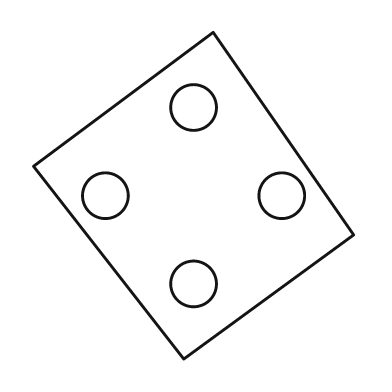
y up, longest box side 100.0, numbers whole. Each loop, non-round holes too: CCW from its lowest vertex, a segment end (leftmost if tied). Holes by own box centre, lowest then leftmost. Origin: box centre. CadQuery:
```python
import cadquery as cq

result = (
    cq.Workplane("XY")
    .moveTo(-3.0, -50.0)
    .lineTo(49.0, -12.0)
    .lineTo(6.0, 50.0)
    .lineTo(-49.0, 9.0)
    .close()
    .moveTo(0.0, -27.0)
    .circle(7.0)
    .moveTo(-27.0, 0.0)
    .circle(7.0)
    .moveTo(27.0, 0.0)
    .circle(7.0)
    .moveTo(0.0, 27.0)
    .circle(7.0)
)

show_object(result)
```